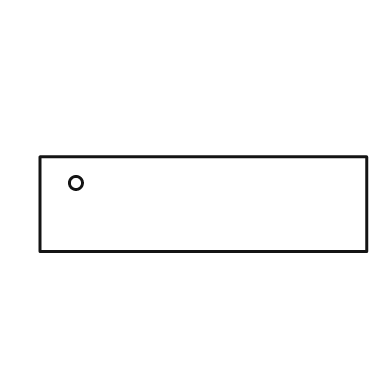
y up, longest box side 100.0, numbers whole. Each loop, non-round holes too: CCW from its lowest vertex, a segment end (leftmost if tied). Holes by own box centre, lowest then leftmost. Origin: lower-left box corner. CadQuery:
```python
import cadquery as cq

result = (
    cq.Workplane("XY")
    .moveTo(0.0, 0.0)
    .lineTo(100.0, 0.0)
    .lineTo(100.0, 29.0)
    .lineTo(0.0, 29.0)
    .close()
    .moveTo(11.0, 21.0)
    .circle(2.0)
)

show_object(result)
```